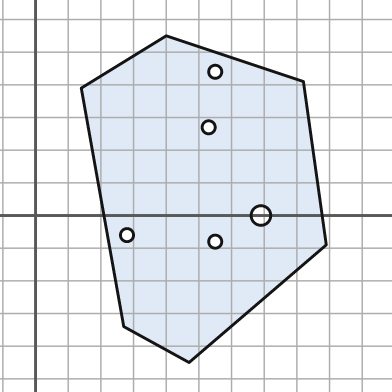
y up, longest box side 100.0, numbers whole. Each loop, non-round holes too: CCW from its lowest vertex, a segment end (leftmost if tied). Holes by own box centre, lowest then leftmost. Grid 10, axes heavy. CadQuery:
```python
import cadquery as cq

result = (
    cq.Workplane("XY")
    .moveTo(47.0, -45.0)
    .lineTo(89.0, -9.0)
    .lineTo(82.0, 41.0)
    .lineTo(40.0, 55.0)
    .lineTo(14.0, 39.0)
    .lineTo(27.0, -34.0)
    .close()
    .moveTo(55.0, -8.0)
    .circle(2.0)
    .moveTo(28.0, -6.0)
    .circle(2.0)
    .moveTo(69.0, 0.0)
    .circle(3.0)
    .moveTo(53.0, 27.0)
    .circle(2.0)
    .moveTo(55.0, 44.0)
    .circle(2.0)
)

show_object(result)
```